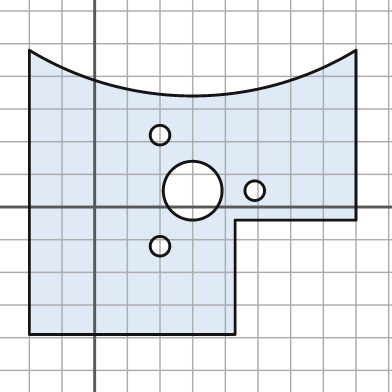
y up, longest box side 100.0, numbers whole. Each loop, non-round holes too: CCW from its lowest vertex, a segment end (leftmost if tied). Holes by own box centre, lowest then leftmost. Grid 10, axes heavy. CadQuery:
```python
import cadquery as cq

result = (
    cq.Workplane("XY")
    .moveTo(-20.0, -39.0)
    .lineTo(43.0, -39.0)
    .lineTo(43.0, -4.0)
    .lineTo(80.0, -4.0)
    .lineTo(80.0, 48.0)
    .threePointArc((30.0, 34.0), (-20.0, 48.0))
    .close()
    .moveTo(20.0, -12.0)
    .circle(3.0)
    .moveTo(30.0, 5.0)
    .circle(9.0)
    .moveTo(49.0, 5.0)
    .circle(3.0)
    .moveTo(20.0, 22.0)
    .circle(3.0)
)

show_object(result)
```